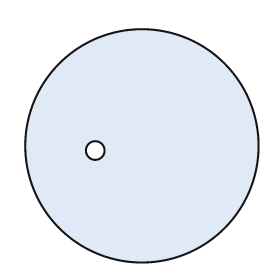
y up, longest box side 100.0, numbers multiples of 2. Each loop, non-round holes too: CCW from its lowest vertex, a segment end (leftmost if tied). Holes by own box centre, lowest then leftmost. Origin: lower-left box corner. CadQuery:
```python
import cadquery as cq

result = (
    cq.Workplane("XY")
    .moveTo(50.0, 50.0)
    .circle(50.0)
    .moveTo(30.0, 48.0)
    .circle(4.0)
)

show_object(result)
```